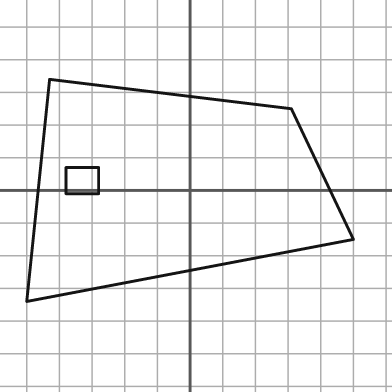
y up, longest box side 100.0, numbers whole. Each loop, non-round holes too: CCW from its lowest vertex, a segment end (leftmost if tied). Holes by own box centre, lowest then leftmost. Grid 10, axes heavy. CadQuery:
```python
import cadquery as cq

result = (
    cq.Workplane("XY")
    .moveTo(-50.0, -34.0)
    .lineTo(50.0, -15.0)
    .lineTo(31.0, 25.0)
    .lineTo(-43.0, 34.0)
    .close()
    .moveTo(-38.0, -1.0)
    .lineTo(-28.0, -1.0)
    .lineTo(-28.0, 7.0)
    .lineTo(-38.0, 7.0)
    .close()
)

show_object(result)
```